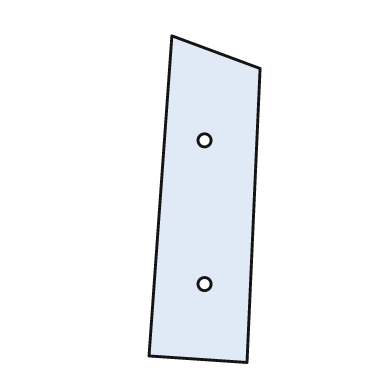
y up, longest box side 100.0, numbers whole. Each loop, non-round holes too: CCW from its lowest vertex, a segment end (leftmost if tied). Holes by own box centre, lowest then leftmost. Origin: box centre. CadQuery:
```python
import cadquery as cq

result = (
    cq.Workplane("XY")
    .moveTo(13.0, -50.0)
    .lineTo(17.0, 40.0)
    .lineTo(-10.0, 50.0)
    .lineTo(-17.0, -48.0)
    .close()
    .moveTo(0.0, -26.0)
    .circle(2.0)
    .moveTo(0.0, 18.0)
    .circle(2.0)
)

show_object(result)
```